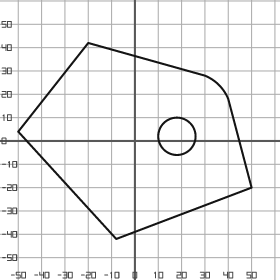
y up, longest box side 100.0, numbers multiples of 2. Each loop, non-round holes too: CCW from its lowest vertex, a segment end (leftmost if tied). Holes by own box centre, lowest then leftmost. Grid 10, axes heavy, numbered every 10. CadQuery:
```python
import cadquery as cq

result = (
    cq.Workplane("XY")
    .moveTo(-8.0, -42.0)
    .lineTo(50.0, -20.0)
    .lineTo(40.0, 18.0)
    .threePointArc((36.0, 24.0), (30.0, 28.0))
    .lineTo(-20.0, 42.0)
    .lineTo(-50.0, 4.0)
    .close()
    .moveTo(18.0, 2.0)
    .circle(8.0)
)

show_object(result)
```